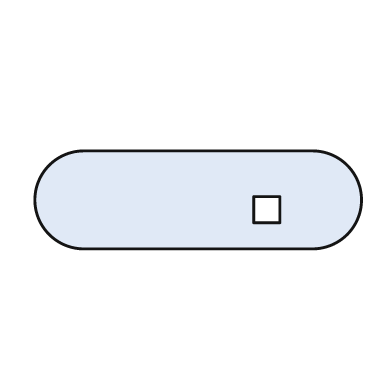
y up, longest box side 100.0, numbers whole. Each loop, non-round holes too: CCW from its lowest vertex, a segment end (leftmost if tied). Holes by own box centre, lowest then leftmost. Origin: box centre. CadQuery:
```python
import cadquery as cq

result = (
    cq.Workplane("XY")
    .moveTo(-35.0, -15.0)
    .lineTo(35.0, -15.0)
    .threePointArc((50.0, 0.0), (35.0, 15.0))
    .lineTo(-35.0, 15.0)
    .threePointArc((-50.0, 0.0), (-35.0, -15.0))
    .close()
    .moveTo(17.0, -7.0)
    .lineTo(25.0, -7.0)
    .lineTo(25.0, 1.0)
    .lineTo(17.0, 1.0)
    .close()
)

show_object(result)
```